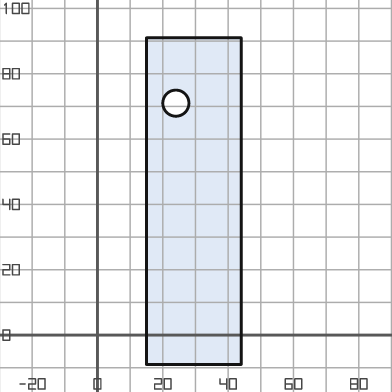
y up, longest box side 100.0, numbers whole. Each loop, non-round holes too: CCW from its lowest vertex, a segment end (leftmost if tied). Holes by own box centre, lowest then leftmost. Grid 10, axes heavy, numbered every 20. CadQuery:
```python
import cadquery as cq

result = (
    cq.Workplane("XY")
    .moveTo(15.0, -9.0)
    .lineTo(44.0, -9.0)
    .lineTo(44.0, 91.0)
    .lineTo(15.0, 91.0)
    .close()
    .moveTo(24.0, 71.0)
    .circle(4.0)
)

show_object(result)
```